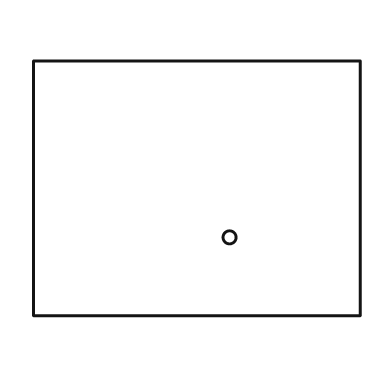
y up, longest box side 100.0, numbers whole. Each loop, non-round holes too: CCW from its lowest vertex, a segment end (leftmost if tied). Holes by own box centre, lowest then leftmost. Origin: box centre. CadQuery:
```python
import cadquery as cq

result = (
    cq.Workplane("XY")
    .moveTo(-50.0, -39.0)
    .lineTo(50.0, -39.0)
    .lineTo(50.0, 39.0)
    .lineTo(-50.0, 39.0)
    .close()
    .moveTo(10.0, -15.0)
    .circle(2.0)
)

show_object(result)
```